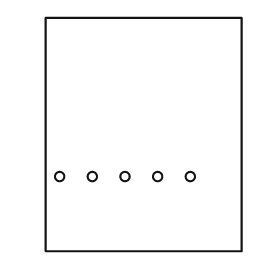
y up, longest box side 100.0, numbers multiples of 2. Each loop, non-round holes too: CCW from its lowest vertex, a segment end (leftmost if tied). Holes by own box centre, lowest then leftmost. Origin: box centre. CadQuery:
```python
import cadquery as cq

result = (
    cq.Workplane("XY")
    .moveTo(-42.0, -50.0)
    .lineTo(42.0, -50.0)
    .lineTo(42.0, 50.0)
    .lineTo(-42.0, 50.0)
    .close()
    .moveTo(-36.0, -18.0)
    .circle(2.0)
    .moveTo(-22.0, -18.0)
    .circle(2.0)
    .moveTo(-8.0, -18.0)
    .circle(2.0)
    .moveTo(6.0, -18.0)
    .circle(2.0)
    .moveTo(20.0, -18.0)
    .circle(2.0)
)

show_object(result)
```